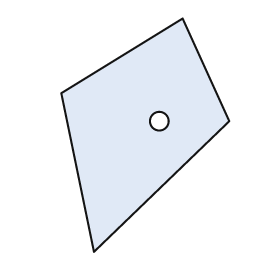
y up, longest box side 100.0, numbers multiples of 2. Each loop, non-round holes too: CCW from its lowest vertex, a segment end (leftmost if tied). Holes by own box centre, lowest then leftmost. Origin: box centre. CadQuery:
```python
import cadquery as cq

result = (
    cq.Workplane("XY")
    .moveTo(-22.0, -50.0)
    .lineTo(36.0, 6.0)
    .lineTo(16.0, 50.0)
    .lineTo(-36.0, 18.0)
    .close()
    .moveTo(6.0, 6.0)
    .circle(4.0)
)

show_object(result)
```